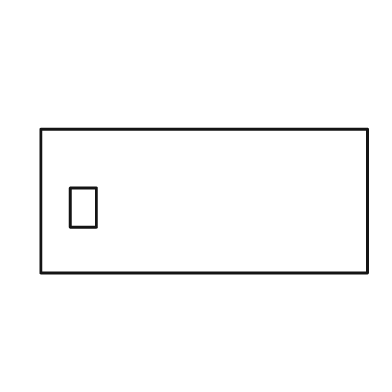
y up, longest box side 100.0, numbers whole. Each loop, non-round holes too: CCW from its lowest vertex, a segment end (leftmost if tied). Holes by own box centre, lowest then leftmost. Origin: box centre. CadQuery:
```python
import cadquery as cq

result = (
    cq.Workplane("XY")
    .moveTo(-50.0, -22.0)
    .lineTo(50.0, -22.0)
    .lineTo(50.0, 22.0)
    .lineTo(-50.0, 22.0)
    .close()
    .moveTo(-41.0, -8.0)
    .lineTo(-33.0, -8.0)
    .lineTo(-33.0, 4.0)
    .lineTo(-41.0, 4.0)
    .close()
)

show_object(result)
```